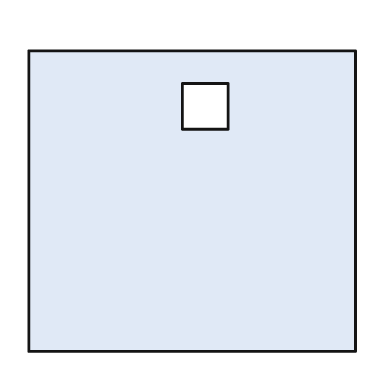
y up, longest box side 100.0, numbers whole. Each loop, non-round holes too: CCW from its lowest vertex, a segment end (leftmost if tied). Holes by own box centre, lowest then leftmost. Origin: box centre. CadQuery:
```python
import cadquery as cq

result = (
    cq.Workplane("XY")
    .moveTo(-50.0, -46.0)
    .lineTo(50.0, -46.0)
    .lineTo(50.0, 46.0)
    .lineTo(-50.0, 46.0)
    .close()
    .moveTo(-3.0, 22.0)
    .lineTo(11.0, 22.0)
    .lineTo(11.0, 36.0)
    .lineTo(-3.0, 36.0)
    .close()
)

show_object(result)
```